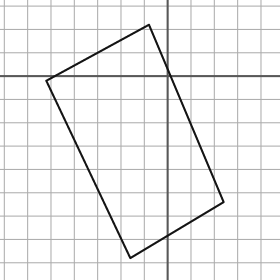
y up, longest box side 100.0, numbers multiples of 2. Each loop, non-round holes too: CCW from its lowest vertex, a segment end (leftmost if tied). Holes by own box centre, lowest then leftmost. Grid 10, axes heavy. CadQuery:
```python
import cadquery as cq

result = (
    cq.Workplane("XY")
    .moveTo(-16.0, -78.0)
    .lineTo(24.0, -54.0)
    .lineTo(-8.0, 22.0)
    .lineTo(-52.0, -2.0)
    .close()
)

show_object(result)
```